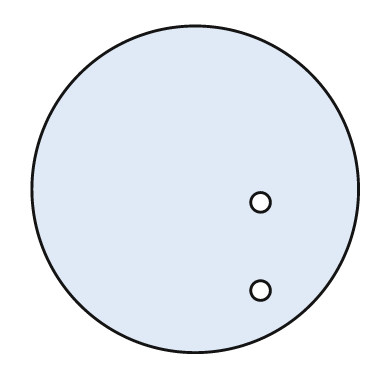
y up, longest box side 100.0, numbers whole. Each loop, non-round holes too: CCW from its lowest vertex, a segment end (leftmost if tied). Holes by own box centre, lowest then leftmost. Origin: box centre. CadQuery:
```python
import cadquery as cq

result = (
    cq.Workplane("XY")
    .moveTo(0.0, 0.0)
    .circle(50.0)
    .moveTo(20.0, -31.0)
    .circle(3.0)
    .moveTo(20.0, -4.0)
    .circle(3.0)
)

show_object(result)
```